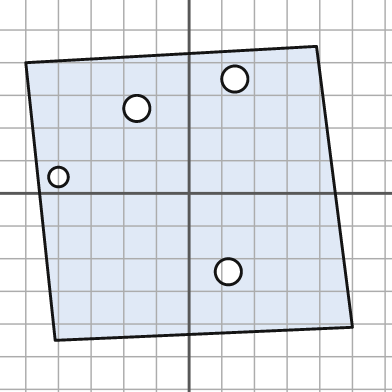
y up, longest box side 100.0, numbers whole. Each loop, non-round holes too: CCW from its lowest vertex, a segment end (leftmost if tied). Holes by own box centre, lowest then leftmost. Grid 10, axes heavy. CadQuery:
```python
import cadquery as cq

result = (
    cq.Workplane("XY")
    .moveTo(-41.0, -45.0)
    .lineTo(50.0, -41.0)
    .lineTo(39.0, 45.0)
    .lineTo(-50.0, 40.0)
    .close()
    .moveTo(12.0, -24.0)
    .circle(4.0)
    .moveTo(-40.0, 5.0)
    .circle(3.0)
    .moveTo(-16.0, 26.0)
    .circle(4.0)
    .moveTo(14.0, 35.0)
    .circle(4.0)
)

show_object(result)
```